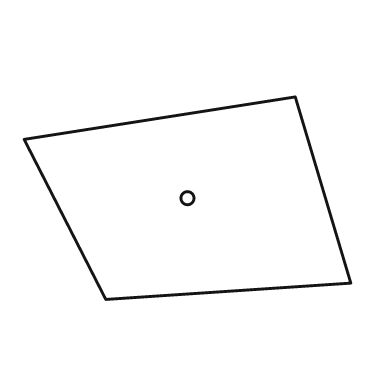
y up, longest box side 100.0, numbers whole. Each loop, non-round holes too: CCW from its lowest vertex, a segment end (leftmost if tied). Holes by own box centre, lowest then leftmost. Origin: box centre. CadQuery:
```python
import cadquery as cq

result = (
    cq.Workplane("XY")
    .moveTo(-25.0, -31.0)
    .lineTo(50.0, -26.0)
    .lineTo(33.0, 31.0)
    .lineTo(-50.0, 18.0)
    .close()
    .moveTo(0.0, 0.0)
    .circle(2.0)
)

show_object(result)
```